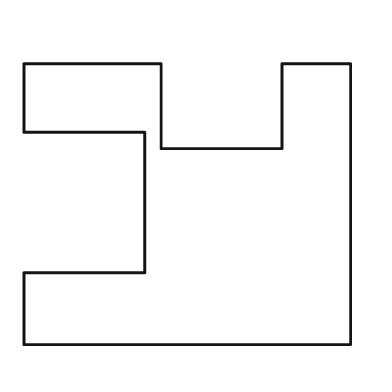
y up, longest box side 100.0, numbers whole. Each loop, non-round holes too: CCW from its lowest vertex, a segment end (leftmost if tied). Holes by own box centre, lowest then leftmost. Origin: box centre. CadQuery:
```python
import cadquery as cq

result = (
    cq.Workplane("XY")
    .moveTo(-50.0, -43.0)
    .lineTo(50.0, -43.0)
    .lineTo(50.0, 43.0)
    .lineTo(29.0, 43.0)
    .lineTo(29.0, 17.0)
    .lineTo(-8.0, 17.0)
    .lineTo(-8.0, 43.0)
    .lineTo(-50.0, 43.0)
    .lineTo(-50.0, 22.0)
    .lineTo(-13.0, 22.0)
    .lineTo(-13.0, -21.0)
    .lineTo(-50.0, -21.0)
    .close()
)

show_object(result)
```